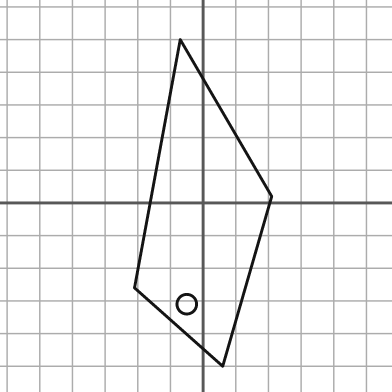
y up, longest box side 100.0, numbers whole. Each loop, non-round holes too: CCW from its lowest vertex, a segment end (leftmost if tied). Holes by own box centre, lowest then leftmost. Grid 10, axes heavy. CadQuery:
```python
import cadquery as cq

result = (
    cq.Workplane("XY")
    .moveTo(6.0, -50.0)
    .lineTo(21.0, 2.0)
    .lineTo(-7.0, 50.0)
    .lineTo(-21.0, -26.0)
    .close()
    .moveTo(-5.0, -31.0)
    .circle(3.0)
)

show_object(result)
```